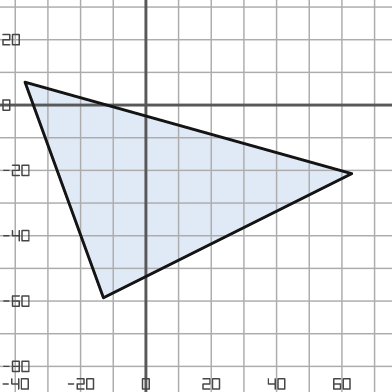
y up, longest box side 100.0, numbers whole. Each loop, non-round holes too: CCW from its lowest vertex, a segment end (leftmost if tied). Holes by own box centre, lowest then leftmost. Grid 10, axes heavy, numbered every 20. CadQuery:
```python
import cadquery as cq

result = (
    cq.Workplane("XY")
    .moveTo(-13.0, -59.0)
    .lineTo(63.0, -21.0)
    .lineTo(-37.0, 7.0)
    .close()
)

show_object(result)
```